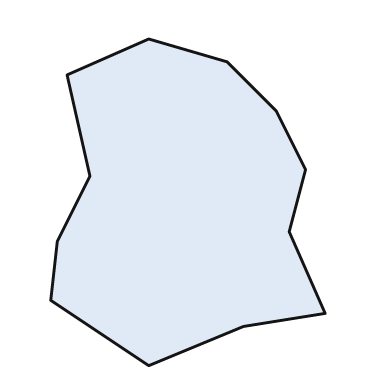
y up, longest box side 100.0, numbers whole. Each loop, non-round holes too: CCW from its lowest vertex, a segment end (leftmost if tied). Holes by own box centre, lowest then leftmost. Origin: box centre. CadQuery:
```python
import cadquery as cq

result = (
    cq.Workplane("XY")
    .moveTo(-12.0, -50.0)
    .lineTo(17.0, -38.0)
    .lineTo(42.0, -34.0)
    .lineTo(31.0, -9.0)
    .lineTo(36.0, 10.0)
    .lineTo(27.0, 28.0)
    .lineTo(12.0, 43.0)
    .lineTo(-12.0, 50.0)
    .lineTo(-37.0, 39.0)
    .lineTo(-30.0, 8.0)
    .lineTo(-40.0, -12.0)
    .lineTo(-42.0, -30.0)
    .close()
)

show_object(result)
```